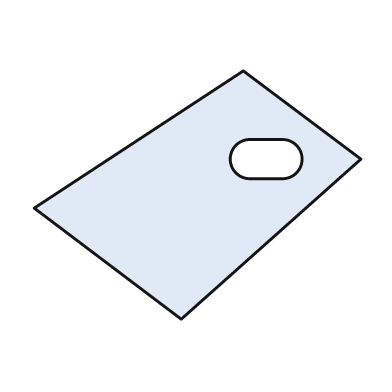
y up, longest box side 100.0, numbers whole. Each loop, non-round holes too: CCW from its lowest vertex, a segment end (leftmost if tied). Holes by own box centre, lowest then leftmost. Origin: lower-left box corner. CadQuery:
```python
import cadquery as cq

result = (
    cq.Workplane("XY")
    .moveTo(45.0, 0.0)
    .lineTo(100.0, 49.0)
    .lineTo(64.0, 76.0)
    .lineTo(0.0, 34.0)
    .close()
    .moveTo(66.0, 43.0)
    .lineTo(76.0, 43.0)
    .threePointArc((82.0, 49.0), (76.0, 55.0))
    .lineTo(66.0, 55.0)
    .threePointArc((60.0, 49.0), (66.0, 43.0))
    .close()
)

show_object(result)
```